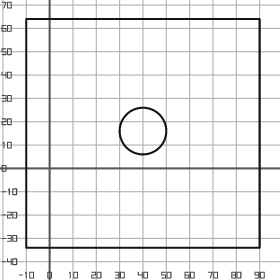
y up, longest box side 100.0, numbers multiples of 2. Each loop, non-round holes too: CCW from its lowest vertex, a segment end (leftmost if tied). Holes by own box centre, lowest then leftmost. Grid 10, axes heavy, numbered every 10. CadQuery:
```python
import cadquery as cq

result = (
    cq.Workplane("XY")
    .moveTo(-10.0, -34.0)
    .lineTo(90.0, -34.0)
    .lineTo(90.0, 64.0)
    .lineTo(-10.0, 64.0)
    .close()
    .moveTo(40.0, 16.0)
    .circle(10.0)
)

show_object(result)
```